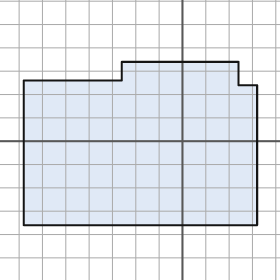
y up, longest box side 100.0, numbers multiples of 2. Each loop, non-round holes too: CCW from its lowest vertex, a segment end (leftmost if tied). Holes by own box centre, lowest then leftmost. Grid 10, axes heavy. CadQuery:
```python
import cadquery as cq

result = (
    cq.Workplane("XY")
    .moveTo(-68.0, -36.0)
    .lineTo(32.0, -36.0)
    .lineTo(32.0, 24.0)
    .lineTo(24.0, 24.0)
    .lineTo(24.0, 34.0)
    .lineTo(-26.0, 34.0)
    .lineTo(-26.0, 26.0)
    .lineTo(-68.0, 26.0)
    .close()
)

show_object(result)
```